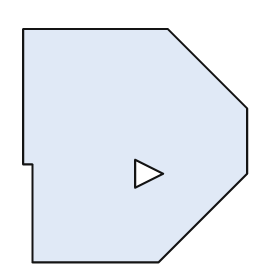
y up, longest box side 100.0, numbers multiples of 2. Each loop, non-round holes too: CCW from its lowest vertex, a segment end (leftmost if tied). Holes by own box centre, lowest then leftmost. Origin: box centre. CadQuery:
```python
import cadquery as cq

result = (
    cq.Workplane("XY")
    .moveTo(-44.0, -50.0)
    .lineTo(10.0, -50.0)
    .lineTo(48.0, -12.0)
    .lineTo(48.0, 16.0)
    .lineTo(14.0, 50.0)
    .lineTo(-48.0, 50.0)
    .lineTo(-48.0, -8.0)
    .lineTo(-44.0, -8.0)
    .close()
    .moveTo(0.0, -18.0)
    .lineTo(12.0, -12.0)
    .lineTo(0.0, -6.0)
    .close()
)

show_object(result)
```